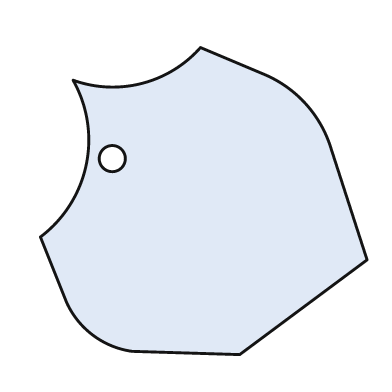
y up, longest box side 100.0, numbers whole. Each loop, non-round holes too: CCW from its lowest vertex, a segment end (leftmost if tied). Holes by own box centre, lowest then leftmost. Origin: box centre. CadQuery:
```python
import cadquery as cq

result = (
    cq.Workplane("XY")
    .moveTo(11.0, -47.0)
    .lineTo(50.0, -18.0)
    .lineTo(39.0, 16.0)
    .threePointArc((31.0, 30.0), (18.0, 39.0))
    .lineTo(-1.0, 47.0)
    .threePointArc((-19.0, 36.0), (-40.0, 37.0))
    .threePointArc((-36.0, 11.0), (-50.0, -11.0))
    .lineTo(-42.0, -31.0)
    .threePointArc((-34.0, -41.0), (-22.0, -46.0))
    .close()
    .moveTo(-28.0, 13.0)
    .circle(4.0)
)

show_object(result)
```